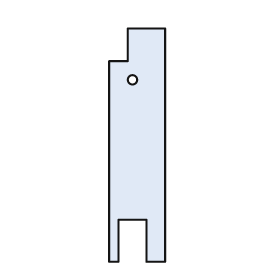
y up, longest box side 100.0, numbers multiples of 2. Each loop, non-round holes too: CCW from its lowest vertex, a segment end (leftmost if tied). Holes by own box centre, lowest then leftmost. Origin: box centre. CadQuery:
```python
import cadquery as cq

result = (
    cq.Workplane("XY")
    .moveTo(-12.0, -50.0)
    .lineTo(-8.0, -50.0)
    .lineTo(-8.0, -32.0)
    .lineTo(4.0, -32.0)
    .lineTo(4.0, -50.0)
    .lineTo(12.0, -50.0)
    .lineTo(12.0, 50.0)
    .lineTo(-4.0, 50.0)
    .lineTo(-4.0, 36.0)
    .lineTo(-12.0, 36.0)
    .close()
    .moveTo(-2.0, 28.0)
    .circle(2.0)
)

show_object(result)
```